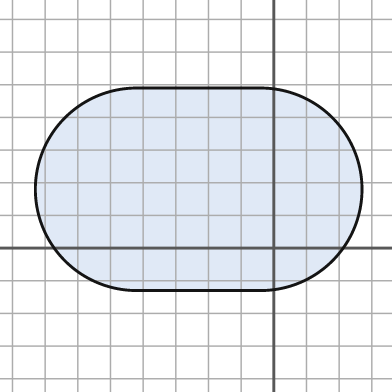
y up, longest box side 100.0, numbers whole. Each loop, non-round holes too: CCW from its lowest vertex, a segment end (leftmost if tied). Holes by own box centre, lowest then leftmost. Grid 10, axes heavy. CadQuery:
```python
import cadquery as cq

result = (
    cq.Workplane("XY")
    .moveTo(-42.0, -13.0)
    .lineTo(-4.0, -13.0)
    .threePointArc((27.0, 18.0), (-4.0, 49.0))
    .lineTo(-42.0, 49.0)
    .threePointArc((-73.0, 18.0), (-42.0, -13.0))
    .close()
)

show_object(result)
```